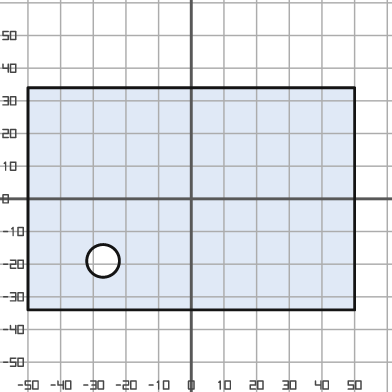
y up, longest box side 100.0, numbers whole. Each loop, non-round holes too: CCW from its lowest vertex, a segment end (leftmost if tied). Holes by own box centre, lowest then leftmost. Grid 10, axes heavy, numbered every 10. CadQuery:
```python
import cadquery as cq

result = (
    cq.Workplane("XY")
    .moveTo(-50.0, -34.0)
    .lineTo(50.0, -34.0)
    .lineTo(50.0, 34.0)
    .lineTo(-50.0, 34.0)
    .close()
    .moveTo(-27.0, -19.0)
    .circle(5.0)
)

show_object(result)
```